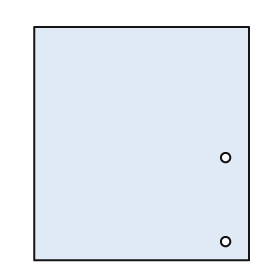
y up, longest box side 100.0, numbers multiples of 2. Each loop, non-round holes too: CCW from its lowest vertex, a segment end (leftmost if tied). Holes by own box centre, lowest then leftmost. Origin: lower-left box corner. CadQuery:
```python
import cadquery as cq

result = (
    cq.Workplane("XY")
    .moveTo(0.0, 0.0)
    .lineTo(92.0, 0.0)
    .lineTo(92.0, 100.0)
    .lineTo(0.0, 100.0)
    .close()
    .moveTo(82.0, 8.0)
    .circle(2.0)
    .moveTo(82.0, 44.0)
    .circle(2.0)
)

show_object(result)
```